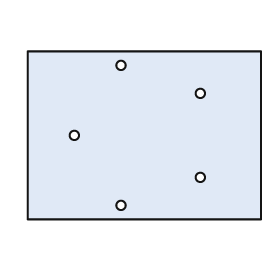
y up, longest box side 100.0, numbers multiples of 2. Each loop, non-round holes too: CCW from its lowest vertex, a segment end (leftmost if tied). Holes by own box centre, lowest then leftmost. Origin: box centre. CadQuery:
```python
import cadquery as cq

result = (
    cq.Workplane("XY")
    .moveTo(-50.0, -36.0)
    .lineTo(50.0, -36.0)
    .lineTo(50.0, 36.0)
    .lineTo(-50.0, 36.0)
    .close()
    .moveTo(-10.0, -30.0)
    .circle(2.0)
    .moveTo(24.0, -18.0)
    .circle(2.0)
    .moveTo(-30.0, 0.0)
    .circle(2.0)
    .moveTo(24.0, 18.0)
    .circle(2.0)
    .moveTo(-10.0, 30.0)
    .circle(2.0)
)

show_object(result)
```